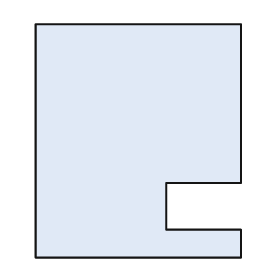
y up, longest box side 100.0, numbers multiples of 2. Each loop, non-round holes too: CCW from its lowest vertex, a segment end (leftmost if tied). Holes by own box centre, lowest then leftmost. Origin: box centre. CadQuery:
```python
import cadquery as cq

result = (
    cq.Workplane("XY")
    .moveTo(-44.0, -50.0)
    .lineTo(44.0, -50.0)
    .lineTo(44.0, -38.0)
    .lineTo(12.0, -38.0)
    .lineTo(12.0, -18.0)
    .lineTo(44.0, -18.0)
    .lineTo(44.0, 50.0)
    .lineTo(-44.0, 50.0)
    .close()
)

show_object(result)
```